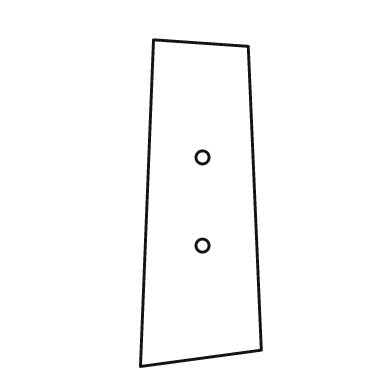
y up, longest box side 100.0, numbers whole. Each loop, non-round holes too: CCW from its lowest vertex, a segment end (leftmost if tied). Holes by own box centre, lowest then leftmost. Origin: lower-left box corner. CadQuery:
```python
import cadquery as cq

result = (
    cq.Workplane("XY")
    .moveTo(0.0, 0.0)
    .lineTo(37.0, 5.0)
    .lineTo(33.0, 98.0)
    .lineTo(4.0, 100.0)
    .close()
    .moveTo(19.0, 37.0)
    .circle(2.0)
    .moveTo(19.0, 64.0)
    .circle(2.0)
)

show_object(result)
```